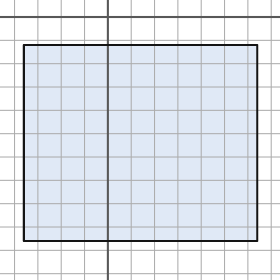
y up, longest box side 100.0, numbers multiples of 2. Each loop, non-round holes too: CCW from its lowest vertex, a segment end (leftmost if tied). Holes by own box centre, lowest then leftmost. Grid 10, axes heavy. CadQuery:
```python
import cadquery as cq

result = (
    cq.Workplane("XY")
    .moveTo(-36.0, -96.0)
    .lineTo(64.0, -96.0)
    .lineTo(64.0, -12.0)
    .lineTo(-36.0, -12.0)
    .close()
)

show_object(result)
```